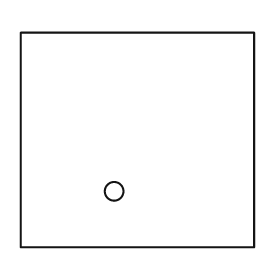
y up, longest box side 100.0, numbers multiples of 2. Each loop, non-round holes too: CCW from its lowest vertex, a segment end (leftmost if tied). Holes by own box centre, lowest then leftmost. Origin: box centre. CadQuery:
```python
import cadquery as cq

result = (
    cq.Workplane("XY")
    .moveTo(-50.0, -46.0)
    .lineTo(50.0, -46.0)
    .lineTo(50.0, 46.0)
    .lineTo(-50.0, 46.0)
    .close()
    .moveTo(-10.0, -22.0)
    .circle(4.0)
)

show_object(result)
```